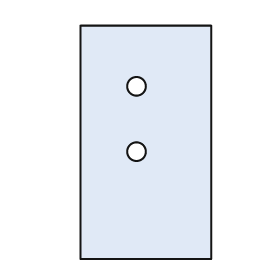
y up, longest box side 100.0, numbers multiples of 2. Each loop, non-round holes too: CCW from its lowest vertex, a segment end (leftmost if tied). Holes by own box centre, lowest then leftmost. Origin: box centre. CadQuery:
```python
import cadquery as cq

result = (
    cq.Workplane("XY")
    .moveTo(-28.0, -50.0)
    .lineTo(28.0, -50.0)
    .lineTo(28.0, 50.0)
    .lineTo(-28.0, 50.0)
    .close()
    .moveTo(-4.0, -4.0)
    .circle(4.0)
    .moveTo(-4.0, 24.0)
    .circle(4.0)
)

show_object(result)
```